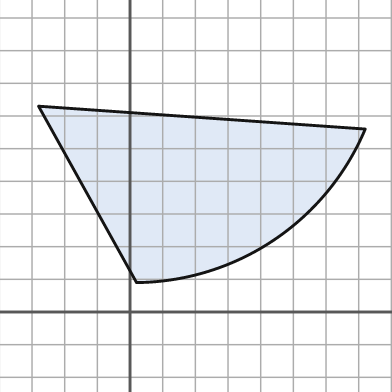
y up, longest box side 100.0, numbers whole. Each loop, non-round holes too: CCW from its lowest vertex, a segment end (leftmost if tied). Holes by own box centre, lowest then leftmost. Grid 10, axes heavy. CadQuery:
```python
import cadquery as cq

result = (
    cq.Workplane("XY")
    .moveTo(2.0, 9.0)
    .threePointArc((44.0, 22.0), (72.0, 56.0))
    .lineTo(-28.0, 63.0)
    .close()
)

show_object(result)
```